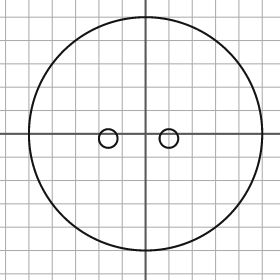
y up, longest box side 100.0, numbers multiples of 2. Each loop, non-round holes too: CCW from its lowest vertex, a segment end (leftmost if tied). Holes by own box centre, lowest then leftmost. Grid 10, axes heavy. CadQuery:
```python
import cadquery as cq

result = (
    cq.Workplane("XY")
    .moveTo(0.0, 0.0)
    .circle(50.0)
    .moveTo(-16.0, -2.0)
    .circle(4.0)
    .moveTo(10.0, -2.0)
    .circle(4.0)
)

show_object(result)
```